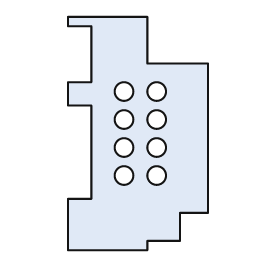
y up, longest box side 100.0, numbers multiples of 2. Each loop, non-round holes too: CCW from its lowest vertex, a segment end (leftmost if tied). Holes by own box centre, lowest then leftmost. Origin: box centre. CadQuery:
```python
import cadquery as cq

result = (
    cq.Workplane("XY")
    .moveTo(-30.0, -50.0)
    .lineTo(4.0, -50.0)
    .lineTo(4.0, -46.0)
    .lineTo(18.0, -46.0)
    .lineTo(18.0, -34.0)
    .lineTo(30.0, -34.0)
    .lineTo(30.0, 30.0)
    .lineTo(4.0, 30.0)
    .lineTo(4.0, 50.0)
    .lineTo(-30.0, 50.0)
    .lineTo(-30.0, 46.0)
    .lineTo(-20.0, 46.0)
    .lineTo(-20.0, 22.0)
    .lineTo(-30.0, 22.0)
    .lineTo(-30.0, 12.0)
    .lineTo(-20.0, 12.0)
    .lineTo(-20.0, -28.0)
    .lineTo(-30.0, -28.0)
    .close()
    .moveTo(-6.0, -18.0)
    .circle(4.0)
    .moveTo(8.0, -18.0)
    .circle(4.0)
    .moveTo(-6.0, -6.0)
    .circle(4.0)
    .moveTo(8.0, -6.0)
    .circle(4.0)
    .moveTo(-6.0, 6.0)
    .circle(4.0)
    .moveTo(8.0, 6.0)
    .circle(4.0)
    .moveTo(-6.0, 18.0)
    .circle(4.0)
    .moveTo(8.0, 18.0)
    .circle(4.0)
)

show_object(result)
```